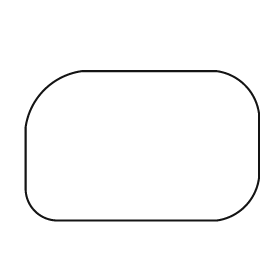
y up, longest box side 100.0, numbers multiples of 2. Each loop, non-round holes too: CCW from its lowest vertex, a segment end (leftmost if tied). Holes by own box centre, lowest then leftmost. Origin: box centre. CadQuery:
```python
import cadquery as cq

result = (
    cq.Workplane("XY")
    .moveTo(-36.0, -32.0)
    .lineTo(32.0, -32.0)
    .threePointArc((44.0, -26.0), (50.0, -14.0))
    .lineTo(50.0, 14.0)
    .threePointArc((44.0, 26.0), (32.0, 32.0))
    .lineTo(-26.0, 32.0)
    .threePointArc((-42.0, 24.0), (-50.0, 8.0))
    .lineTo(-50.0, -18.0)
    .threePointArc((-46.0, -28.0), (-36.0, -32.0))
    .close()
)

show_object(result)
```